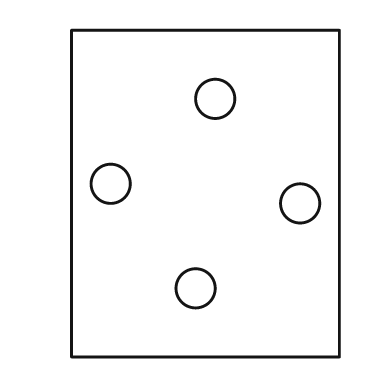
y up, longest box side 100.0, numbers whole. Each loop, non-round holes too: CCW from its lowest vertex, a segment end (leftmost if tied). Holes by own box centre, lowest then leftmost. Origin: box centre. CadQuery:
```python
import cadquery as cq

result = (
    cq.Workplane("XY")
    .moveTo(-41.0, -50.0)
    .lineTo(41.0, -50.0)
    .lineTo(41.0, 50.0)
    .lineTo(-41.0, 50.0)
    .close()
    .moveTo(-3.0, -29.0)
    .circle(6.0)
    .moveTo(29.0, -3.0)
    .circle(6.0)
    .moveTo(-29.0, 3.0)
    .circle(6.0)
    .moveTo(3.0, 29.0)
    .circle(6.0)
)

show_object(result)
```